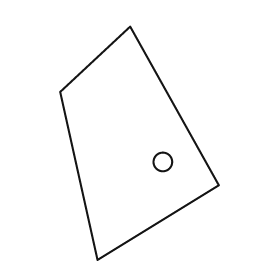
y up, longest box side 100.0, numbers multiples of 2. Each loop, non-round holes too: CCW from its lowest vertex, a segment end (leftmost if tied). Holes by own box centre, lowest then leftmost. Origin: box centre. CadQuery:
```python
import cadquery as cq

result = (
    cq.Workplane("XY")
    .moveTo(-18.0, -50.0)
    .lineTo(34.0, -18.0)
    .lineTo(-4.0, 50.0)
    .lineTo(-34.0, 22.0)
    .close()
    .moveTo(10.0, -8.0)
    .circle(4.0)
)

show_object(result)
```